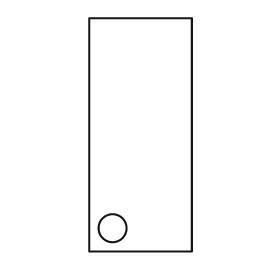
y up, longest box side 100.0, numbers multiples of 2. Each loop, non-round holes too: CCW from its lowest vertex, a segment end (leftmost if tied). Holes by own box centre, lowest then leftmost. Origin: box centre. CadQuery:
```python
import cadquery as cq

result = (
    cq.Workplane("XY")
    .moveTo(-22.0, -50.0)
    .lineTo(22.0, -50.0)
    .lineTo(22.0, 50.0)
    .lineTo(-22.0, 50.0)
    .close()
    .moveTo(-12.0, -40.0)
    .circle(6.0)
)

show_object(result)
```